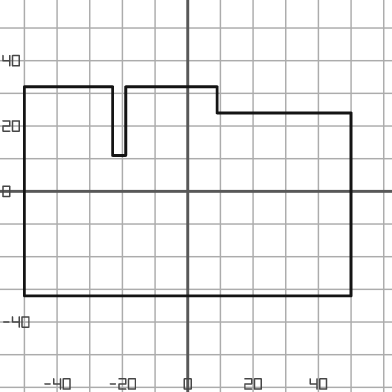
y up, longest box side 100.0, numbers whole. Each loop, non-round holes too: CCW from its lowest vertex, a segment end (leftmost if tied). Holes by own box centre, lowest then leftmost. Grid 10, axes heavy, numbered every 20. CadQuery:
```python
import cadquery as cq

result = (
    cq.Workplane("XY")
    .moveTo(-50.0, -32.0)
    .lineTo(50.0, -32.0)
    .lineTo(50.0, 24.0)
    .lineTo(9.0, 24.0)
    .lineTo(9.0, 32.0)
    .lineTo(-19.0, 32.0)
    .lineTo(-19.0, 11.0)
    .lineTo(-23.0, 11.0)
    .lineTo(-23.0, 32.0)
    .lineTo(-50.0, 32.0)
    .close()
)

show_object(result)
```